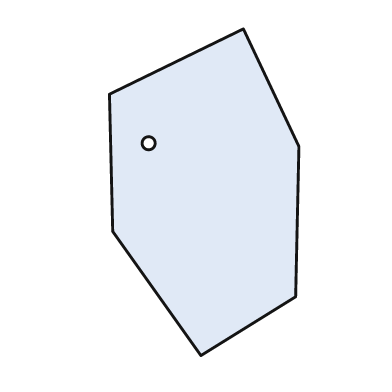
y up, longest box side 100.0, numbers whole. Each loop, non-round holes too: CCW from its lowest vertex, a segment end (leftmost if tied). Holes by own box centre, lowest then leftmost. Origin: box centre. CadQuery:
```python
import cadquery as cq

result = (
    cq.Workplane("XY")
    .moveTo(-1.0, -50.0)
    .lineTo(28.0, -32.0)
    .lineTo(29.0, 14.0)
    .lineTo(12.0, 50.0)
    .lineTo(-29.0, 30.0)
    .lineTo(-28.0, -12.0)
    .close()
    .moveTo(-17.0, 15.0)
    .circle(2.0)
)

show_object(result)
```